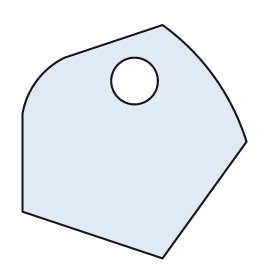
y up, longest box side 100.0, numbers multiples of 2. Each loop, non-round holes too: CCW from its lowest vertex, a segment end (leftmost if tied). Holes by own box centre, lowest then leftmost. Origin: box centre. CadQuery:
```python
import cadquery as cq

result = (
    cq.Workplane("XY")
    .moveTo(12.0, -50.0)
    .lineTo(48.0, 0.0)
    .threePointArc((34.0, 28.0), (12.0, 50.0))
    .lineTo(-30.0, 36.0)
    .threePointArc((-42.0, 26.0), (-48.0, 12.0))
    .lineTo(-48.0, -30.0)
    .close()
    .moveTo(0.0, 26.0)
    .circle(10.0)
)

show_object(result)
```